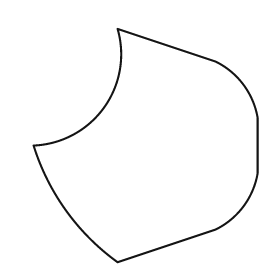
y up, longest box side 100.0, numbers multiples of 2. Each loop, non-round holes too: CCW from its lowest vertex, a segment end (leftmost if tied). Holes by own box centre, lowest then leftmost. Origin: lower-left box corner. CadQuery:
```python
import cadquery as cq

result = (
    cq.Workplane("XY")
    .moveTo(36.0, 0.0)
    .lineTo(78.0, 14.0)
    .threePointArc((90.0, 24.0), (96.0, 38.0))
    .lineTo(96.0, 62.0)
    .threePointArc((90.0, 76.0), (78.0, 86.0))
    .lineTo(36.0, 100.0)
    .threePointArc((30.0, 66.0), (0.0, 50.0))
    .threePointArc((14.0, 22.0), (36.0, 0.0))
    .close()
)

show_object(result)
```